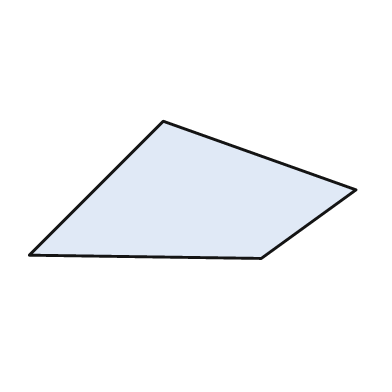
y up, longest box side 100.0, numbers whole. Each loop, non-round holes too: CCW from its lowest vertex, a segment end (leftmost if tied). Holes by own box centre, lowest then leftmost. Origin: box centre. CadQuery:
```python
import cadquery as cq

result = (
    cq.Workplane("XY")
    .moveTo(21.0, -21.0)
    .lineTo(50.0, 0.0)
    .lineTo(-9.0, 21.0)
    .lineTo(-50.0, -20.0)
    .close()
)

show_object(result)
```